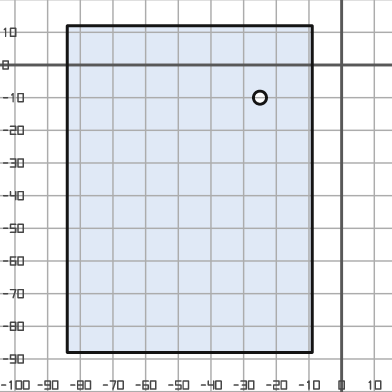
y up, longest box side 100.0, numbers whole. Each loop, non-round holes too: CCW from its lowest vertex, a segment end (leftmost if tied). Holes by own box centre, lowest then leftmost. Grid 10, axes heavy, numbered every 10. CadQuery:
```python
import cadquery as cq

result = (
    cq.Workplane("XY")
    .moveTo(-84.0, -88.0)
    .lineTo(-9.0, -88.0)
    .lineTo(-9.0, 12.0)
    .lineTo(-84.0, 12.0)
    .close()
    .moveTo(-25.0, -10.0)
    .circle(2.0)
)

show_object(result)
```